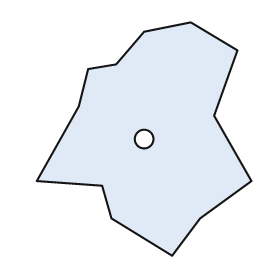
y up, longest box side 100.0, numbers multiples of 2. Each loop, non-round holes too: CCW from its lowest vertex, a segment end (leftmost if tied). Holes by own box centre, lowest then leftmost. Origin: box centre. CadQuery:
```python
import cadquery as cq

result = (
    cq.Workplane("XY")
    .moveTo(12.0, -50.0)
    .lineTo(24.0, -34.0)
    .lineTo(46.0, -18.0)
    .lineTo(30.0, 10.0)
    .lineTo(40.0, 38.0)
    .lineTo(20.0, 50.0)
    .lineTo(0.0, 46.0)
    .lineTo(-12.0, 32.0)
    .lineTo(-24.0, 30.0)
    .lineTo(-28.0, 14.0)
    .lineTo(-46.0, -18.0)
    .lineTo(-18.0, -20.0)
    .lineTo(-14.0, -34.0)
    .close()
    .moveTo(0.0, 0.0)
    .circle(4.0)
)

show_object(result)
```